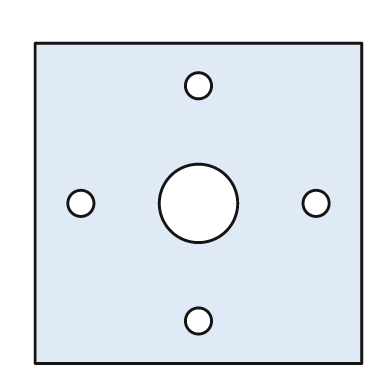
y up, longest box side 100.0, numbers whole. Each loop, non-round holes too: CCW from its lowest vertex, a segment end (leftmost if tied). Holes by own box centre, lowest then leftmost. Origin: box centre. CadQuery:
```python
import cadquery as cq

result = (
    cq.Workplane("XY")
    .moveTo(-50.0, -49.0)
    .lineTo(50.0, -49.0)
    .lineTo(50.0, 49.0)
    .lineTo(-50.0, 49.0)
    .close()
    .moveTo(0.0, -36.0)
    .circle(4.0)
    .moveTo(-36.0, 0.0)
    .circle(4.0)
    .moveTo(0.0, 0.0)
    .circle(12.0)
    .moveTo(36.0, 0.0)
    .circle(4.0)
    .moveTo(0.0, 36.0)
    .circle(4.0)
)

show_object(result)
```